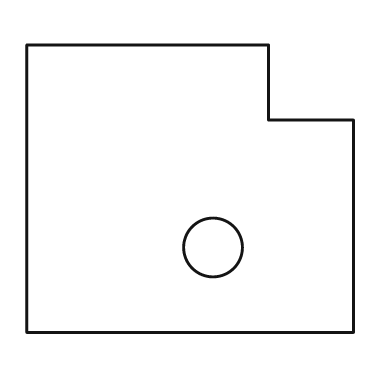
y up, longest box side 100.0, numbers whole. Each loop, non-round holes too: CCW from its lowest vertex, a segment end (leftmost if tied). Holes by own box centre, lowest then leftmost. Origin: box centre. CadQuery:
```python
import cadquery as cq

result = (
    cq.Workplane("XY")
    .moveTo(-50.0, -44.0)
    .lineTo(50.0, -44.0)
    .lineTo(50.0, 21.0)
    .lineTo(24.0, 21.0)
    .lineTo(24.0, 44.0)
    .lineTo(-50.0, 44.0)
    .close()
    .moveTo(7.0, -18.0)
    .circle(9.0)
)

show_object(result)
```